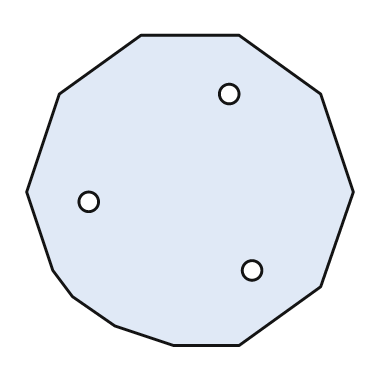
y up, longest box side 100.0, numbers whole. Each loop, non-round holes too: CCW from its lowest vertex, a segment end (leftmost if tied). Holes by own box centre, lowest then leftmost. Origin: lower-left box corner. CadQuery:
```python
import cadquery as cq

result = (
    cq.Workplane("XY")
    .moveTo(45.0, 0.0)
    .lineTo(65.0, 0.0)
    .lineTo(90.0, 18.0)
    .lineTo(100.0, 47.0)
    .lineTo(90.0, 77.0)
    .lineTo(65.0, 95.0)
    .lineTo(35.0, 95.0)
    .lineTo(10.0, 77.0)
    .lineTo(0.0, 47.0)
    .lineTo(8.0, 23.0)
    .lineTo(14.0, 15.0)
    .lineTo(27.0, 6.0)
    .close()
    .moveTo(69.0, 23.0)
    .circle(3.0)
    .moveTo(19.0, 44.0)
    .circle(3.0)
    .moveTo(62.0, 77.0)
    .circle(3.0)
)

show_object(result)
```